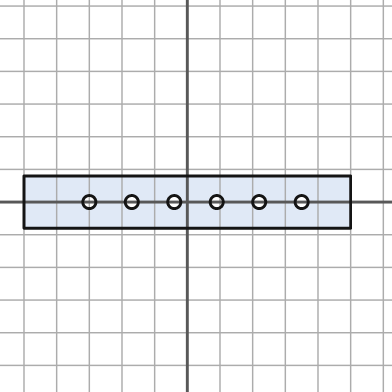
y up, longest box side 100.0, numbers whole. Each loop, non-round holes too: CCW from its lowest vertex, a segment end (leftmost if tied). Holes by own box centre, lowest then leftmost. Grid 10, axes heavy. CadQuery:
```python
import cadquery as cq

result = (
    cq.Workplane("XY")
    .moveTo(-50.0, -8.0)
    .lineTo(50.0, -8.0)
    .lineTo(50.0, 8.0)
    .lineTo(-50.0, 8.0)
    .close()
    .moveTo(-30.0, 0.0)
    .circle(2.0)
    .moveTo(-17.0, 0.0)
    .circle(2.0)
    .moveTo(-4.0, 0.0)
    .circle(2.0)
    .moveTo(9.0, 0.0)
    .circle(2.0)
    .moveTo(22.0, 0.0)
    .circle(2.0)
    .moveTo(35.0, 0.0)
    .circle(2.0)
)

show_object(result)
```